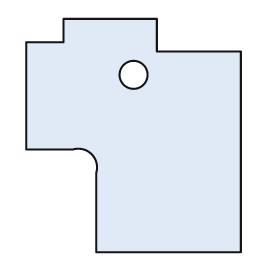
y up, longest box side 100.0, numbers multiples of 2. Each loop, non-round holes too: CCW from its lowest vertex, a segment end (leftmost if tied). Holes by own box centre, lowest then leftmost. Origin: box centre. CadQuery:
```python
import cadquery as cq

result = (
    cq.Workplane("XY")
    .moveTo(-16.0, -50.0)
    .lineTo(46.0, -50.0)
    .lineTo(46.0, 36.0)
    .lineTo(10.0, 36.0)
    .lineTo(10.0, 50.0)
    .lineTo(-30.0, 50.0)
    .lineTo(-30.0, 40.0)
    .lineTo(-46.0, 40.0)
    .lineTo(-46.0, -6.0)
    .lineTo(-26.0, -6.0)
    .threePointArc((-18.0, -8.0), (-16.0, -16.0))
    .close()
    .moveTo(0.0, 26.0)
    .circle(6.0)
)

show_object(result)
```